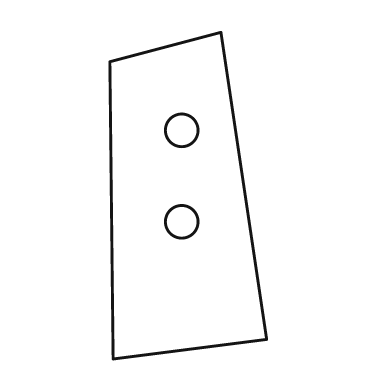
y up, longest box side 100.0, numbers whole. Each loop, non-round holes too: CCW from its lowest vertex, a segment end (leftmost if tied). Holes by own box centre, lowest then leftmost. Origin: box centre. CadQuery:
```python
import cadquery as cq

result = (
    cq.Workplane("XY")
    .moveTo(-23.0, -50.0)
    .lineTo(24.0, -44.0)
    .lineTo(10.0, 50.0)
    .lineTo(-24.0, 41.0)
    .close()
    .moveTo(-2.0, -8.0)
    .circle(5.0)
    .moveTo(-2.0, 20.0)
    .circle(5.0)
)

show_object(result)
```